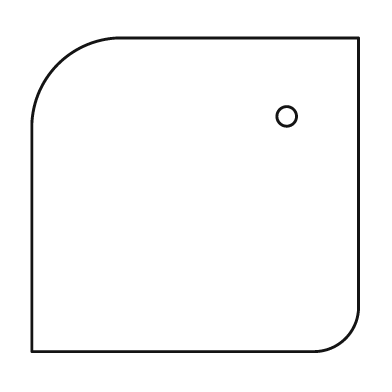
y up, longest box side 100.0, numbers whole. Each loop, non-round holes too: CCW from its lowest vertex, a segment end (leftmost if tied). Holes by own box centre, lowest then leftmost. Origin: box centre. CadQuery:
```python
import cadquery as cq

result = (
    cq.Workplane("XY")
    .moveTo(-50.0, -48.0)
    .lineTo(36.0, -48.0)
    .threePointArc((46.0, -44.0), (50.0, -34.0))
    .lineTo(50.0, 48.0)
    .lineTo(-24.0, 48.0)
    .threePointArc((-42.0, 40.0), (-50.0, 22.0))
    .close()
    .moveTo(28.0, 24.0)
    .circle(3.0)
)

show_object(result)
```